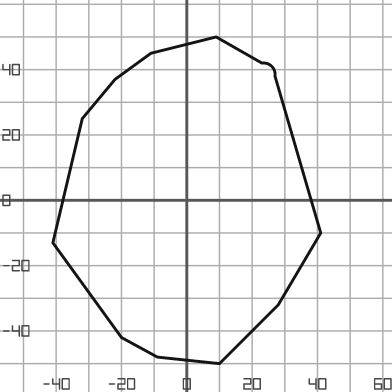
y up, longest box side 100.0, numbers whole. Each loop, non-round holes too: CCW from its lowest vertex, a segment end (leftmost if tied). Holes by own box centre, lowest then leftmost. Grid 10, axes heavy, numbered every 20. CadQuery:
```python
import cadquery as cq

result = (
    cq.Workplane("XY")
    .moveTo(10.0, -50.0)
    .lineTo(28.0, -32.0)
    .lineTo(41.0, -10.0)
    .lineTo(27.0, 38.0)
    .threePointArc((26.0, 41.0), (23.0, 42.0))
    .lineTo(9.0, 50.0)
    .lineTo(-11.0, 45.0)
    .lineTo(-22.0, 37.0)
    .lineTo(-32.0, 25.0)
    .lineTo(-41.0, -13.0)
    .lineTo(-20.0, -42.0)
    .lineTo(-9.0, -48.0)
    .close()
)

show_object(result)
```